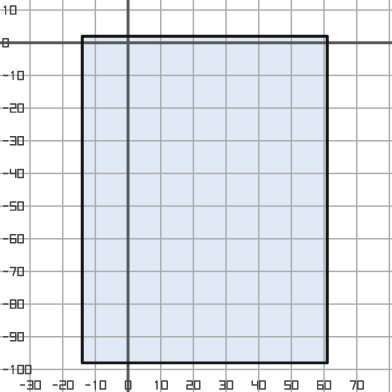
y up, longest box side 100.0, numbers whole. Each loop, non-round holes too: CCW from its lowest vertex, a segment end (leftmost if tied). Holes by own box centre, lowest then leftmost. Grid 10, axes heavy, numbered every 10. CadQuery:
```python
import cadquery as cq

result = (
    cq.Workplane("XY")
    .moveTo(-14.0, -98.0)
    .lineTo(61.0, -98.0)
    .lineTo(61.0, 2.0)
    .lineTo(-14.0, 2.0)
    .close()
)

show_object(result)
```